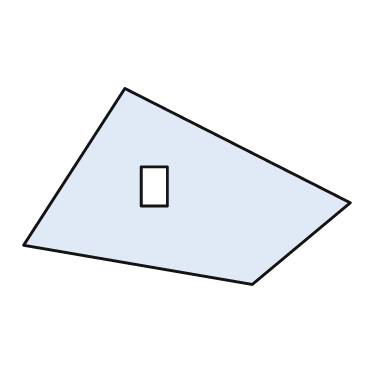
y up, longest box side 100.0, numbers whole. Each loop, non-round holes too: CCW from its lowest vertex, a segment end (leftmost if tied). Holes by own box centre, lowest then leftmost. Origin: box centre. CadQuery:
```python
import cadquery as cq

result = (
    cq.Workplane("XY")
    .moveTo(20.0, -30.0)
    .lineTo(50.0, -5.0)
    .lineTo(-19.0, 30.0)
    .lineTo(-50.0, -18.0)
    .close()
    .moveTo(-14.0, -6.0)
    .lineTo(-6.0, -6.0)
    .lineTo(-6.0, 6.0)
    .lineTo(-14.0, 6.0)
    .close()
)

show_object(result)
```